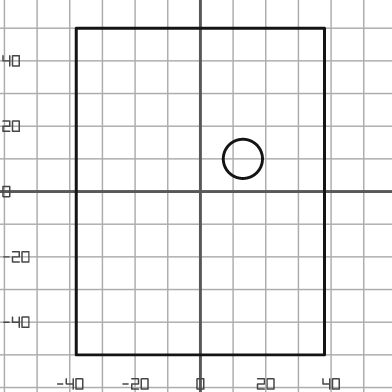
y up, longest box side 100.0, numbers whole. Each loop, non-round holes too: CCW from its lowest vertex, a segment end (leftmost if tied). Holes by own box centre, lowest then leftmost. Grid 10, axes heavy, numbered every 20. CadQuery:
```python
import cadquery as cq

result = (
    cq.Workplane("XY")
    .moveTo(-38.0, -50.0)
    .lineTo(38.0, -50.0)
    .lineTo(38.0, 50.0)
    .lineTo(-38.0, 50.0)
    .close()
    .moveTo(13.0, 10.0)
    .circle(6.0)
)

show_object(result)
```